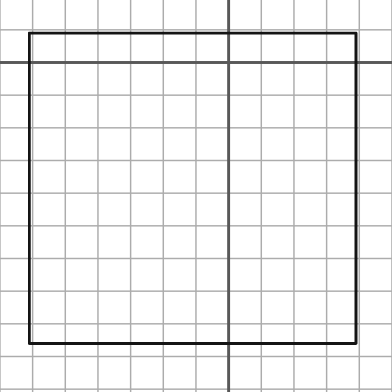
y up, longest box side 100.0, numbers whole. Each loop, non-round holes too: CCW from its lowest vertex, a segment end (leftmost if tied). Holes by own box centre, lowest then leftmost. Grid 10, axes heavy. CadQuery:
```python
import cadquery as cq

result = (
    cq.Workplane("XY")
    .moveTo(-61.0, -86.0)
    .lineTo(39.0, -86.0)
    .lineTo(39.0, 9.0)
    .lineTo(-61.0, 9.0)
    .close()
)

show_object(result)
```